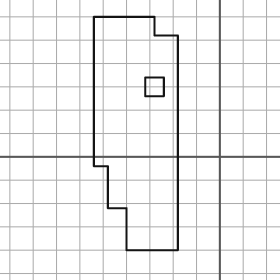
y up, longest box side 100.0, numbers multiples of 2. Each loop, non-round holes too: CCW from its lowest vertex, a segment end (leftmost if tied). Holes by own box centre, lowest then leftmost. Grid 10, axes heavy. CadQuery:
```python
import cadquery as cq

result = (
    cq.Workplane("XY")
    .moveTo(-40.0, -40.0)
    .lineTo(-18.0, -40.0)
    .lineTo(-18.0, 52.0)
    .lineTo(-28.0, 52.0)
    .lineTo(-28.0, 60.0)
    .lineTo(-54.0, 60.0)
    .lineTo(-54.0, -4.0)
    .lineTo(-48.0, -4.0)
    .lineTo(-48.0, -22.0)
    .lineTo(-40.0, -22.0)
    .close()
    .moveTo(-32.0, 26.0)
    .lineTo(-24.0, 26.0)
    .lineTo(-24.0, 34.0)
    .lineTo(-32.0, 34.0)
    .close()
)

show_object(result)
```